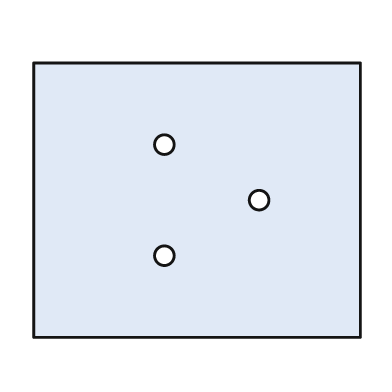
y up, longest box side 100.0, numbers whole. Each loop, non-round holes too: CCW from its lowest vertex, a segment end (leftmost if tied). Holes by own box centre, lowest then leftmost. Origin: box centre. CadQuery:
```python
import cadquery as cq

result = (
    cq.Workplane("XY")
    .moveTo(-50.0, -42.0)
    .lineTo(50.0, -42.0)
    .lineTo(50.0, 42.0)
    .lineTo(-50.0, 42.0)
    .close()
    .moveTo(-10.0, -17.0)
    .circle(3.0)
    .moveTo(19.0, 0.0)
    .circle(3.0)
    .moveTo(-10.0, 17.0)
    .circle(3.0)
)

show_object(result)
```